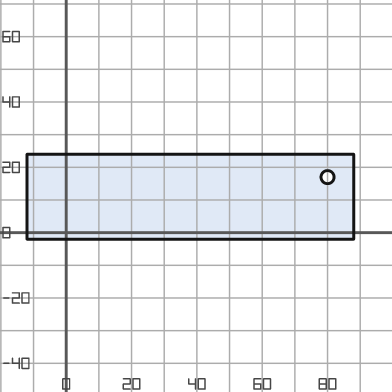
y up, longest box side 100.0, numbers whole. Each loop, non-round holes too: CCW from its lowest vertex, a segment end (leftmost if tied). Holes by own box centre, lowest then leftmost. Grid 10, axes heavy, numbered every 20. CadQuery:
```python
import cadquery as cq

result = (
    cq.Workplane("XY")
    .moveTo(-12.0, -2.0)
    .lineTo(88.0, -2.0)
    .lineTo(88.0, 24.0)
    .lineTo(-12.0, 24.0)
    .close()
    .moveTo(80.0, 17.0)
    .circle(2.0)
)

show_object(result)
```